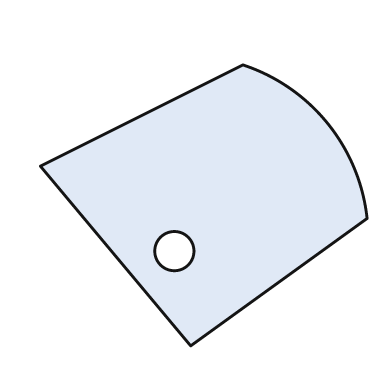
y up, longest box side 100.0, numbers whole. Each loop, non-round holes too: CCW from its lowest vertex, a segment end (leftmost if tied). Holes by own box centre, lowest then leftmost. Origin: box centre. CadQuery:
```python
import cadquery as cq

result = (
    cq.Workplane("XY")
    .moveTo(-4.0, -43.0)
    .lineTo(50.0, -4.0)
    .threePointArc((38.0, 25.0), (12.0, 43.0))
    .lineTo(-50.0, 12.0)
    .close()
    .moveTo(-9.0, -14.0)
    .circle(6.0)
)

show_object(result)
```